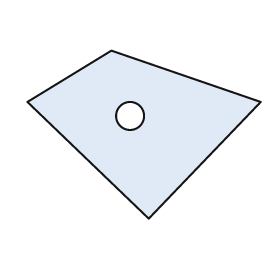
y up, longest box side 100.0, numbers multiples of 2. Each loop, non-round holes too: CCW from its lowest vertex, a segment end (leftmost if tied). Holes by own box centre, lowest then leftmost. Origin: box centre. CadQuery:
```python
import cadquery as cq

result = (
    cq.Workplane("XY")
    .moveTo(2.0, -36.0)
    .lineTo(50.0, 14.0)
    .lineTo(-14.0, 36.0)
    .lineTo(-50.0, 14.0)
    .close()
    .moveTo(-6.0, 8.0)
    .circle(6.0)
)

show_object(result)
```